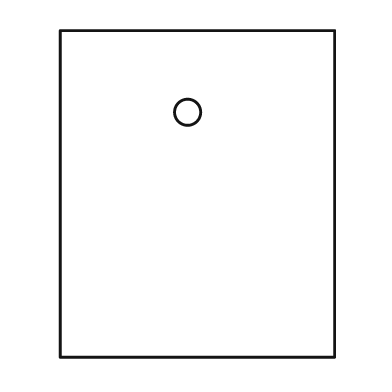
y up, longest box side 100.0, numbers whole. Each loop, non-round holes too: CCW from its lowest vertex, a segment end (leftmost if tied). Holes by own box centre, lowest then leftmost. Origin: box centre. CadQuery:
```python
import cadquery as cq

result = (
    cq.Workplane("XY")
    .moveTo(-42.0, -50.0)
    .lineTo(42.0, -50.0)
    .lineTo(42.0, 50.0)
    .lineTo(-42.0, 50.0)
    .close()
    .moveTo(-3.0, 25.0)
    .circle(4.0)
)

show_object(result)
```